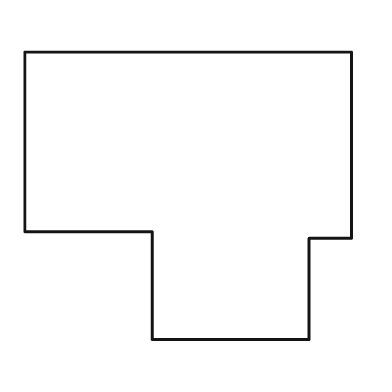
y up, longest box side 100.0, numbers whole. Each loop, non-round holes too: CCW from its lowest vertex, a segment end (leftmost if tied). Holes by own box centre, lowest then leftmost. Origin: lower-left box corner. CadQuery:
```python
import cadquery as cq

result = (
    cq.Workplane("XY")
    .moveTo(39.0, 0.0)
    .lineTo(87.0, 0.0)
    .lineTo(87.0, 31.0)
    .lineTo(100.0, 31.0)
    .lineTo(100.0, 88.0)
    .lineTo(0.0, 88.0)
    .lineTo(0.0, 33.0)
    .lineTo(39.0, 33.0)
    .close()
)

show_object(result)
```